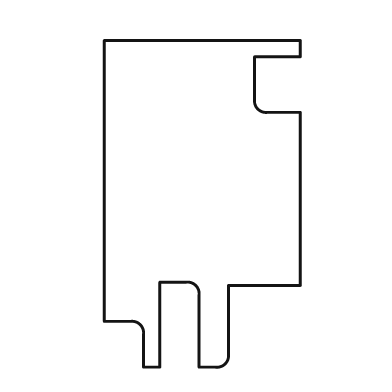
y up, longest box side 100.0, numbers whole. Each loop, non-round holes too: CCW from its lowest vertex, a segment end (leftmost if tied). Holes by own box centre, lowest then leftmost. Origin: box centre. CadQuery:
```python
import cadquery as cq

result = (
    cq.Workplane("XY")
    .moveTo(-18.0, -50.0)
    .lineTo(-13.0, -50.0)
    .lineTo(-13.0, -24.0)
    .lineTo(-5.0, -24.0)
    .threePointArc((-2.0, -25.0), (-1.0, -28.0))
    .lineTo(-1.0, -50.0)
    .lineTo(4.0, -50.0)
    .threePointArc((7.0, -49.0), (8.0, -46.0))
    .lineTo(8.0, -25.0)
    .lineTo(30.0, -25.0)
    .lineTo(30.0, 28.0)
    .lineTo(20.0, 28.0)
    .threePointArc((17.0, 29.0), (16.0, 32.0))
    .lineTo(16.0, 45.0)
    .lineTo(30.0, 45.0)
    .lineTo(30.0, 50.0)
    .lineTo(-30.0, 50.0)
    .lineTo(-30.0, -36.0)
    .lineTo(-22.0, -36.0)
    .threePointArc((-19.0, -37.0), (-18.0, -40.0))
    .close()
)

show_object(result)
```